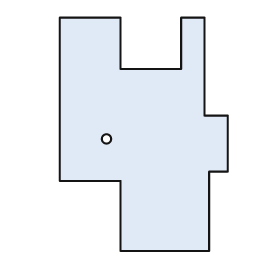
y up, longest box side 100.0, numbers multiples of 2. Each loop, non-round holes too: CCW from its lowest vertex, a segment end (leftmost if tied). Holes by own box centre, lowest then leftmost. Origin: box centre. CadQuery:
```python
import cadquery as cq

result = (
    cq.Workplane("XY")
    .moveTo(-10.0, -50.0)
    .lineTo(28.0, -50.0)
    .lineTo(28.0, -16.0)
    .lineTo(36.0, -16.0)
    .lineTo(36.0, 8.0)
    .lineTo(26.0, 8.0)
    .lineTo(26.0, 50.0)
    .lineTo(16.0, 50.0)
    .lineTo(16.0, 28.0)
    .lineTo(-10.0, 28.0)
    .lineTo(-10.0, 50.0)
    .lineTo(-36.0, 50.0)
    .lineTo(-36.0, -20.0)
    .lineTo(-10.0, -20.0)
    .close()
    .moveTo(-16.0, -2.0)
    .circle(2.0)
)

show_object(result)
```